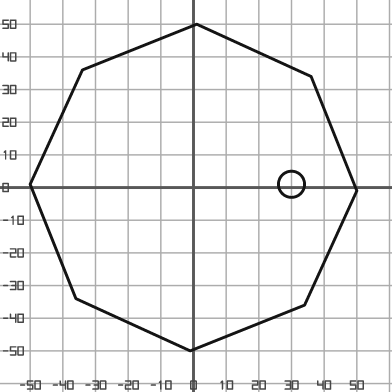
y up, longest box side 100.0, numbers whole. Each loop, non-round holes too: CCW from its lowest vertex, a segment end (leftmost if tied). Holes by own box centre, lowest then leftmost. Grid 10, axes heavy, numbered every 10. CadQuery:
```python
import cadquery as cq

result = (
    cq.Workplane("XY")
    .moveTo(-1.0, -50.0)
    .lineTo(34.0, -36.0)
    .lineTo(50.0, -1.0)
    .lineTo(36.0, 34.0)
    .lineTo(1.0, 50.0)
    .lineTo(-34.0, 36.0)
    .lineTo(-50.0, 1.0)
    .lineTo(-36.0, -34.0)
    .close()
    .moveTo(30.0, 1.0)
    .circle(4.0)
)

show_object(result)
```